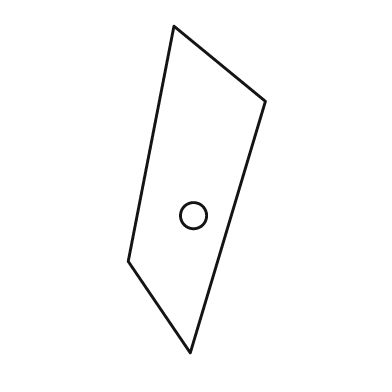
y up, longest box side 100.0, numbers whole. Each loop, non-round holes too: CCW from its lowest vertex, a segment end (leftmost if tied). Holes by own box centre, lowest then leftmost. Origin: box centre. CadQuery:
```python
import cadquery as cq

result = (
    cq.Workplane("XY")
    .moveTo(-2.0, -50.0)
    .lineTo(21.0, 27.0)
    .lineTo(-7.0, 50.0)
    .lineTo(-21.0, -22.0)
    .close()
    .moveTo(-1.0, -8.0)
    .circle(4.0)
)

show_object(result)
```